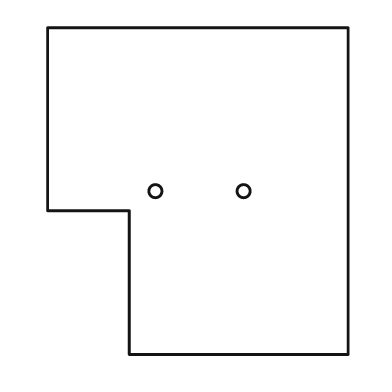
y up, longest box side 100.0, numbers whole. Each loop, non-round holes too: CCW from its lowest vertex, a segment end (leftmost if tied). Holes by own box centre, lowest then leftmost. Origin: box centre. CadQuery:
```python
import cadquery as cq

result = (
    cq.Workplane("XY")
    .moveTo(-21.0, -50.0)
    .lineTo(46.0, -50.0)
    .lineTo(46.0, 50.0)
    .lineTo(-46.0, 50.0)
    .lineTo(-46.0, -6.0)
    .lineTo(-21.0, -6.0)
    .close()
    .moveTo(-13.0, 0.0)
    .circle(2.0)
    .moveTo(14.0, 0.0)
    .circle(2.0)
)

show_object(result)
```